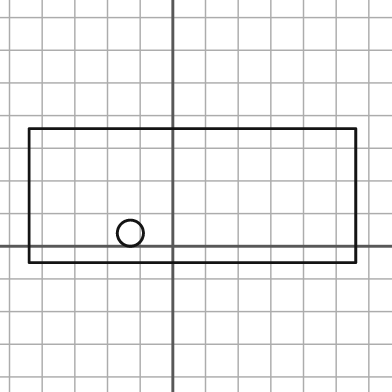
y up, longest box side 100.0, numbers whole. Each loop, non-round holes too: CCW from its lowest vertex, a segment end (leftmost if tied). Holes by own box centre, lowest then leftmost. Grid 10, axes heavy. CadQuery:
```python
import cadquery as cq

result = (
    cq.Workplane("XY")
    .moveTo(-44.0, -5.0)
    .lineTo(56.0, -5.0)
    .lineTo(56.0, 36.0)
    .lineTo(-44.0, 36.0)
    .close()
    .moveTo(-13.0, 4.0)
    .circle(4.0)
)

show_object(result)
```